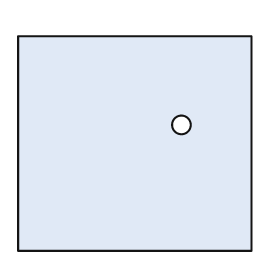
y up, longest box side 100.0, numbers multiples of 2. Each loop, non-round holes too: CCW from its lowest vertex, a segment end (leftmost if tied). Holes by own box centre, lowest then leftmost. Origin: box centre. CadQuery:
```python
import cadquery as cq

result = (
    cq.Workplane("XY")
    .moveTo(-50.0, -46.0)
    .lineTo(50.0, -46.0)
    .lineTo(50.0, 46.0)
    .lineTo(-50.0, 46.0)
    .close()
    .moveTo(20.0, 8.0)
    .circle(4.0)
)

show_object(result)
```